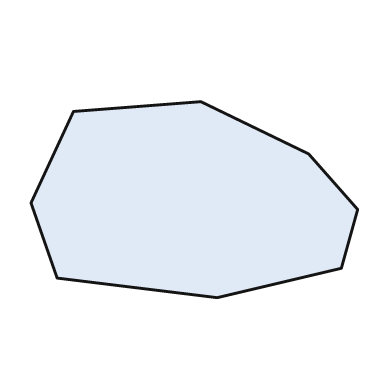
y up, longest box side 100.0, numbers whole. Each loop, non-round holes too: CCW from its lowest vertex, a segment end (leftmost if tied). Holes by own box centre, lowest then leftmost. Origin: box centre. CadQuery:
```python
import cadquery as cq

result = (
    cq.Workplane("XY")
    .moveTo(7.0, -30.0)
    .lineTo(45.0, -21.0)
    .lineTo(50.0, -3.0)
    .lineTo(35.0, 14.0)
    .lineTo(2.0, 30.0)
    .lineTo(-37.0, 27.0)
    .lineTo(-50.0, -1.0)
    .lineTo(-42.0, -24.0)
    .close()
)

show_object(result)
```